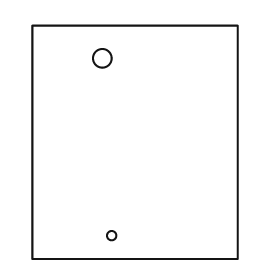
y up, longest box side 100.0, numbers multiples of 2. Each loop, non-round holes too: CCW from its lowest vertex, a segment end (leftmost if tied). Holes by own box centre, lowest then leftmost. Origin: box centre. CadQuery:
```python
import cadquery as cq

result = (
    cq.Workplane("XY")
    .moveTo(-44.0, -50.0)
    .lineTo(44.0, -50.0)
    .lineTo(44.0, 50.0)
    .lineTo(-44.0, 50.0)
    .close()
    .moveTo(-10.0, -40.0)
    .circle(2.0)
    .moveTo(-14.0, 36.0)
    .circle(4.0)
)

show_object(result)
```